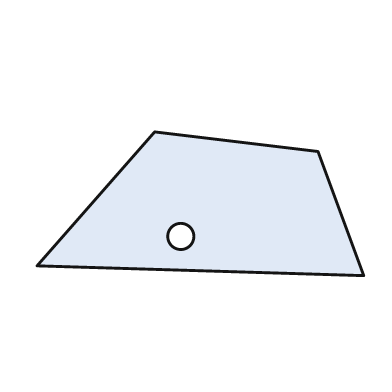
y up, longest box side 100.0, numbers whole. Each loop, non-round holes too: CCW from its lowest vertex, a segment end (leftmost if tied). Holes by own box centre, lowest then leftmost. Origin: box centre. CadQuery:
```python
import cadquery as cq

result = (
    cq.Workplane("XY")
    .moveTo(50.0, -22.0)
    .lineTo(36.0, 16.0)
    .lineTo(-14.0, 22.0)
    .lineTo(-50.0, -19.0)
    .close()
    .moveTo(-6.0, -10.0)
    .circle(4.0)
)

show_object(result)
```